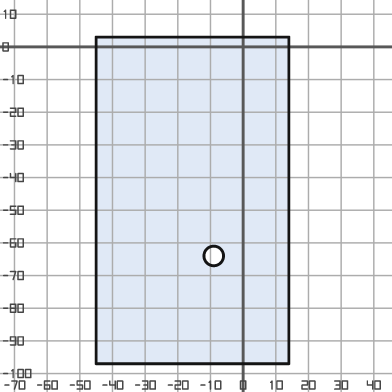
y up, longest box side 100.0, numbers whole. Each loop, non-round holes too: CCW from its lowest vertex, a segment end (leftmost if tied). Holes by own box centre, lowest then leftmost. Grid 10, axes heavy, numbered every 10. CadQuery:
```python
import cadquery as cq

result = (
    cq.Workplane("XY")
    .moveTo(-45.0, -97.0)
    .lineTo(14.0, -97.0)
    .lineTo(14.0, 3.0)
    .lineTo(-45.0, 3.0)
    .close()
    .moveTo(-9.0, -64.0)
    .circle(3.0)
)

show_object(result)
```